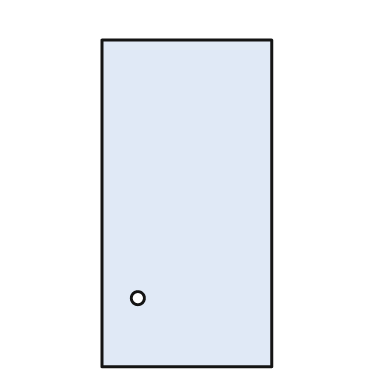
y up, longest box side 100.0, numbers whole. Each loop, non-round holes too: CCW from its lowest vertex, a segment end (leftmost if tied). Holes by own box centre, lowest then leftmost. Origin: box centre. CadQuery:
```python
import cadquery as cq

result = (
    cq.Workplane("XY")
    .moveTo(-26.0, -50.0)
    .lineTo(26.0, -50.0)
    .lineTo(26.0, 50.0)
    .lineTo(-26.0, 50.0)
    .close()
    .moveTo(-15.0, -29.0)
    .circle(2.0)
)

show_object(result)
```